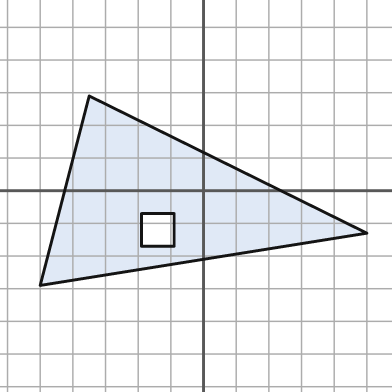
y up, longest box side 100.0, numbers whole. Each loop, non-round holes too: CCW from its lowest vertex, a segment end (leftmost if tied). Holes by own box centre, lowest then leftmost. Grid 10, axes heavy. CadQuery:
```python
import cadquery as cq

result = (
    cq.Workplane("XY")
    .moveTo(-50.0, -29.0)
    .lineTo(50.0, -13.0)
    .lineTo(-35.0, 29.0)
    .close()
    .moveTo(-19.0, -17.0)
    .lineTo(-9.0, -17.0)
    .lineTo(-9.0, -7.0)
    .lineTo(-19.0, -7.0)
    .close()
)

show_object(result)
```